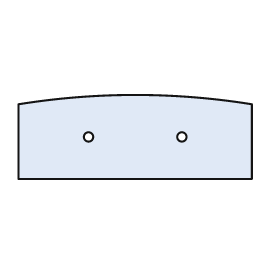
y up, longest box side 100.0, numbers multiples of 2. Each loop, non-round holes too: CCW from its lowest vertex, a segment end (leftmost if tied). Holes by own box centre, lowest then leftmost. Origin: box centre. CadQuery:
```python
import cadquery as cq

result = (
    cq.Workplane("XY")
    .moveTo(-50.0, -18.0)
    .lineTo(50.0, -18.0)
    .lineTo(50.0, 14.0)
    .threePointArc((0.0, 18.0), (-50.0, 14.0))
    .close()
    .moveTo(-20.0, 0.0)
    .circle(2.0)
    .moveTo(20.0, 0.0)
    .circle(2.0)
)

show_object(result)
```